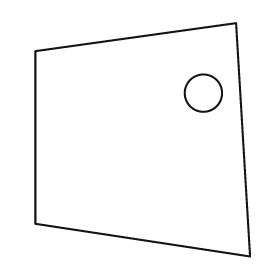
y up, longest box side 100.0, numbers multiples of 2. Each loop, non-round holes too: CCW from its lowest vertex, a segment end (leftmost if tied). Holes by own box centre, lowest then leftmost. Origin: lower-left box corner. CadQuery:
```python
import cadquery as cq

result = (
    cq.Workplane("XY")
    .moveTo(92.0, 0.0)
    .lineTo(86.0, 100.0)
    .lineTo(0.0, 88.0)
    .lineTo(0.0, 14.0)
    .close()
    .moveTo(72.0, 70.0)
    .circle(8.0)
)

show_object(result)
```